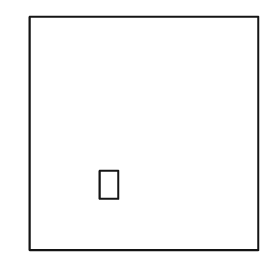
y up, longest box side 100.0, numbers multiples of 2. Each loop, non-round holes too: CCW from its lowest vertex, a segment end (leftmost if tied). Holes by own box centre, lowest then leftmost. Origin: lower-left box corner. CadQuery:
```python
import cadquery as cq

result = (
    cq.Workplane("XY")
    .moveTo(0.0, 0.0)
    .lineTo(98.0, 0.0)
    .lineTo(98.0, 100.0)
    .lineTo(0.0, 100.0)
    .close()
    .moveTo(30.0, 22.0)
    .lineTo(38.0, 22.0)
    .lineTo(38.0, 34.0)
    .lineTo(30.0, 34.0)
    .close()
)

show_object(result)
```